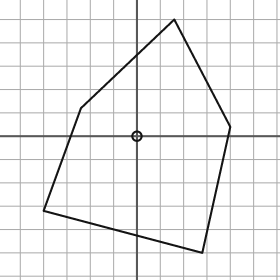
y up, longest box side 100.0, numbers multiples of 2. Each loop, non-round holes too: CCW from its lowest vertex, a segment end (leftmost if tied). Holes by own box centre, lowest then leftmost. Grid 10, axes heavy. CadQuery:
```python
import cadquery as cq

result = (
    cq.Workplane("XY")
    .moveTo(28.0, -50.0)
    .lineTo(40.0, 4.0)
    .lineTo(16.0, 50.0)
    .lineTo(-24.0, 12.0)
    .lineTo(-40.0, -32.0)
    .close()
    .moveTo(0.0, 0.0)
    .circle(2.0)
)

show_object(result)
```